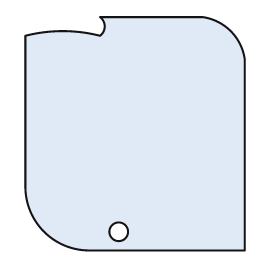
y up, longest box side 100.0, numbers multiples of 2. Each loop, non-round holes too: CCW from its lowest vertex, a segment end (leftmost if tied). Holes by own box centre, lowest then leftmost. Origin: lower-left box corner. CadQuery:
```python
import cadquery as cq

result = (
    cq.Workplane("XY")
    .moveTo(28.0, 0.0)
    .lineTo(94.0, 0.0)
    .lineTo(94.0, 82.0)
    .threePointArc((88.0, 94.0), (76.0, 100.0))
    .lineTo(32.0, 100.0)
    .threePointArc((34.0, 96.0), (32.0, 92.0))
    .threePointArc((16.0, 94.0), (0.0, 92.0))
    .lineTo(0.0, 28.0)
    .threePointArc((8.0, 8.0), (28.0, 0.0))
    .close()
    .moveTo(40.0, 8.0)
    .circle(4.0)
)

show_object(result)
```